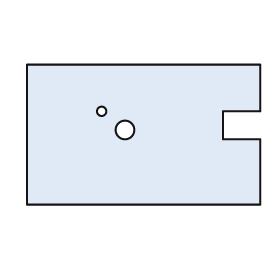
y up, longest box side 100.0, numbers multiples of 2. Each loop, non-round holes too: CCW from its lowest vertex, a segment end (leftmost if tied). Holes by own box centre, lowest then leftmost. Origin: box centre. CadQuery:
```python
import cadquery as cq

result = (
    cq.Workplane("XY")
    .moveTo(-50.0, -30.0)
    .lineTo(50.0, -30.0)
    .lineTo(50.0, -2.0)
    .lineTo(34.0, -2.0)
    .lineTo(34.0, 10.0)
    .lineTo(50.0, 10.0)
    .lineTo(50.0, 30.0)
    .lineTo(-50.0, 30.0)
    .close()
    .moveTo(-8.0, 2.0)
    .circle(4.0)
    .moveTo(-18.0, 10.0)
    .circle(2.0)
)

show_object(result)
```